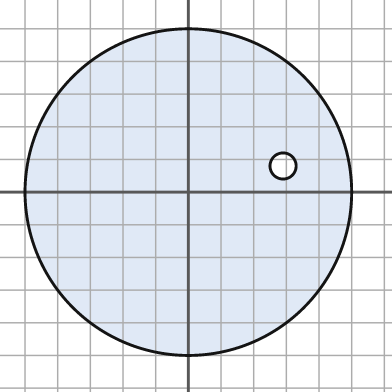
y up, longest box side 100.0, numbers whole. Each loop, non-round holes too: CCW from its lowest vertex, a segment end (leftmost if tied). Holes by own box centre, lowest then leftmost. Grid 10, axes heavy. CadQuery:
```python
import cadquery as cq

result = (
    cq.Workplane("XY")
    .moveTo(0.0, 0.0)
    .circle(50.0)
    .moveTo(29.0, 8.0)
    .circle(4.0)
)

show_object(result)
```